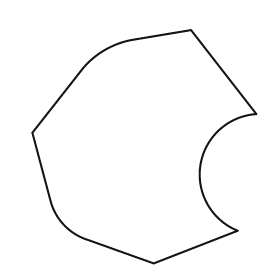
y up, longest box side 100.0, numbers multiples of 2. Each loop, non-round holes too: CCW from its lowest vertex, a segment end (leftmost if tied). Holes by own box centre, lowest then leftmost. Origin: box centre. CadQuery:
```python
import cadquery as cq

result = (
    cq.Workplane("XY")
    .moveTo(4.0, -50.0)
    .lineTo(40.0, -36.0)
    .threePointArc((24.0, -8.0), (48.0, 14.0))
    .lineTo(20.0, 50.0)
    .lineTo(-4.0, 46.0)
    .threePointArc((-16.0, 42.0), (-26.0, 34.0))
    .lineTo(-48.0, 6.0)
    .lineTo(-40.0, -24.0)
    .threePointArc((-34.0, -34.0), (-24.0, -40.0))
    .close()
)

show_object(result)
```